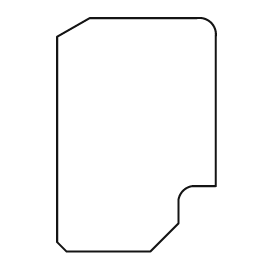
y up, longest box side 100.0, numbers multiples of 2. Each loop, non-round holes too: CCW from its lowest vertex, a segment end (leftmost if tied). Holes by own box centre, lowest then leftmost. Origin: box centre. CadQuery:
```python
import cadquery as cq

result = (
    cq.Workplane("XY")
    .moveTo(-30.0, -50.0)
    .lineTo(6.0, -50.0)
    .lineTo(18.0, -38.0)
    .lineTo(18.0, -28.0)
    .threePointArc((20.0, -24.0), (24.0, -22.0))
    .lineTo(34.0, -22.0)
    .lineTo(34.0, 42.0)
    .threePointArc((32.0, 48.0), (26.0, 50.0))
    .lineTo(-20.0, 50.0)
    .lineTo(-34.0, 42.0)
    .lineTo(-34.0, -46.0)
    .close()
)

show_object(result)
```